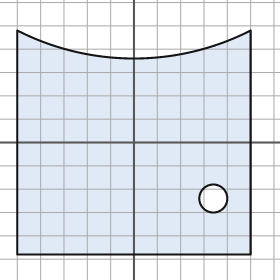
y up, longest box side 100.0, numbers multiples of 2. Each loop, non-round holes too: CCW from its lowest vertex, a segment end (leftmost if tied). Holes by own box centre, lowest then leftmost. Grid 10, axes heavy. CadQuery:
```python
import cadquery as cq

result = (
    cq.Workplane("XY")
    .moveTo(-50.0, -48.0)
    .lineTo(50.0, -48.0)
    .lineTo(50.0, 48.0)
    .threePointArc((0.0, 36.0), (-50.0, 48.0))
    .close()
    .moveTo(34.0, -24.0)
    .circle(6.0)
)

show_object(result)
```